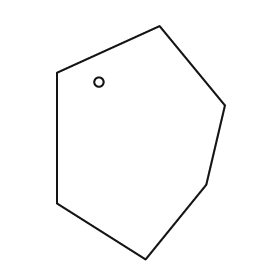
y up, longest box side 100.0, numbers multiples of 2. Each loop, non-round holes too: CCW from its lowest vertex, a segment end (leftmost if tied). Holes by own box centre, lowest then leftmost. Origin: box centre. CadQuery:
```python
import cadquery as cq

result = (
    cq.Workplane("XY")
    .moveTo(2.0, -50.0)
    .lineTo(28.0, -18.0)
    .lineTo(36.0, 16.0)
    .lineTo(8.0, 50.0)
    .lineTo(-36.0, 30.0)
    .lineTo(-36.0, -26.0)
    .close()
    .moveTo(-18.0, 26.0)
    .circle(2.0)
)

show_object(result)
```